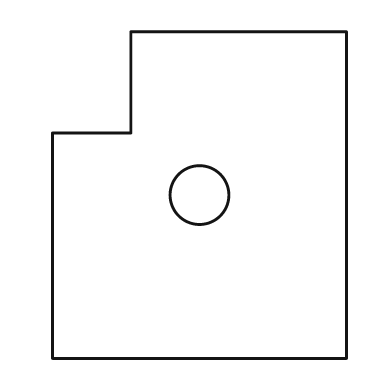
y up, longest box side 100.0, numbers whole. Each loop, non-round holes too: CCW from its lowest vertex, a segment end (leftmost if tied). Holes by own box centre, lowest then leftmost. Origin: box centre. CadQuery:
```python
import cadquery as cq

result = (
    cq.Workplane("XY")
    .moveTo(-45.0, -50.0)
    .lineTo(45.0, -50.0)
    .lineTo(45.0, 50.0)
    .lineTo(-21.0, 50.0)
    .lineTo(-21.0, 19.0)
    .lineTo(-45.0, 19.0)
    .close()
    .moveTo(0.0, 0.0)
    .circle(9.0)
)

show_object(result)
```